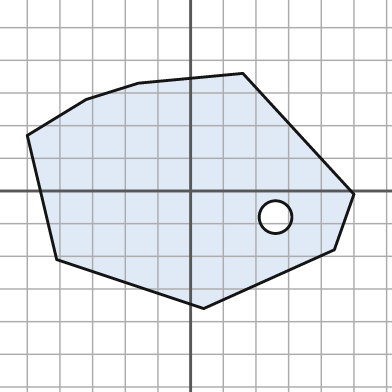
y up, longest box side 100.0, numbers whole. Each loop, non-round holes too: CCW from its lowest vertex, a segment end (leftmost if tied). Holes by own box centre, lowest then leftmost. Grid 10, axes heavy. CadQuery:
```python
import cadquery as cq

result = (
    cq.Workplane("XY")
    .moveTo(4.0, -36.0)
    .lineTo(44.0, -18.0)
    .lineTo(50.0, -1.0)
    .lineTo(16.0, 36.0)
    .lineTo(-16.0, 33.0)
    .lineTo(-32.0, 28.0)
    .lineTo(-50.0, 17.0)
    .lineTo(-41.0, -21.0)
    .close()
    .moveTo(26.0, -8.0)
    .circle(5.0)
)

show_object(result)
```